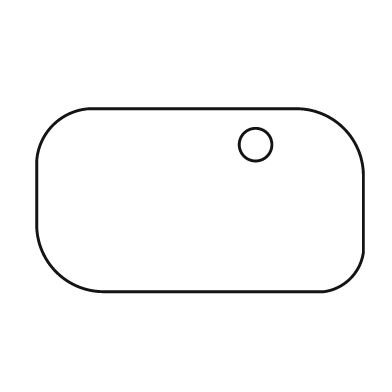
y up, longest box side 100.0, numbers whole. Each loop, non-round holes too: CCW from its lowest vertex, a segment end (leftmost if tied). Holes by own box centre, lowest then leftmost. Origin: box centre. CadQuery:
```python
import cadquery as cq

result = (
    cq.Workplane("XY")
    .moveTo(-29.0, -28.0)
    .lineTo(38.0, -28.0)
    .threePointArc((46.0, -24.0), (50.0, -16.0))
    .lineTo(50.0, 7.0)
    .threePointArc((44.0, 22.0), (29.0, 28.0))
    .lineTo(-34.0, 28.0)
    .threePointArc((-45.0, 23.0), (-50.0, 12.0))
    .lineTo(-50.0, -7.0)
    .threePointArc((-44.0, -22.0), (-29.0, -28.0))
    .close()
    .moveTo(17.0, 17.0)
    .circle(5.0)
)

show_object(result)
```